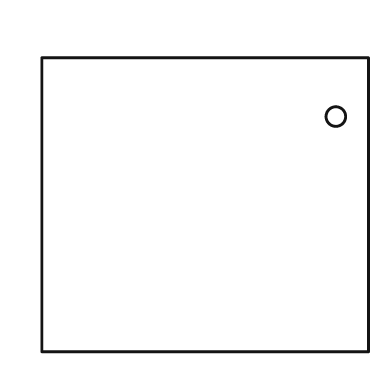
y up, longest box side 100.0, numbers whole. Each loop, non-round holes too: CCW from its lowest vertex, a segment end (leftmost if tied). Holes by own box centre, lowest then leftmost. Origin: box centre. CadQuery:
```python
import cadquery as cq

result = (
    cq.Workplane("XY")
    .moveTo(-50.0, -45.0)
    .lineTo(50.0, -45.0)
    .lineTo(50.0, 45.0)
    .lineTo(-50.0, 45.0)
    .close()
    .moveTo(40.0, 27.0)
    .circle(3.0)
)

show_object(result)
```